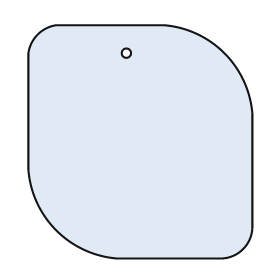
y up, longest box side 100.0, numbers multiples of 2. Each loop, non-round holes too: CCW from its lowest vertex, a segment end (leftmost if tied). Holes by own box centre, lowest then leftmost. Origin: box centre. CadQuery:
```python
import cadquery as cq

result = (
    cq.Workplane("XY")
    .moveTo(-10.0, -50.0)
    .lineTo(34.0, -50.0)
    .threePointArc((44.0, -46.0), (48.0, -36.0))
    .lineTo(48.0, 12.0)
    .threePointArc((36.0, 38.0), (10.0, 50.0))
    .lineTo(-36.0, 50.0)
    .threePointArc((-44.0, 46.0), (-48.0, 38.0))
    .lineTo(-48.0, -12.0)
    .threePointArc((-36.0, -38.0), (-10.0, -50.0))
    .close()
    .moveTo(-6.0, 38.0)
    .circle(2.0)
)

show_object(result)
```